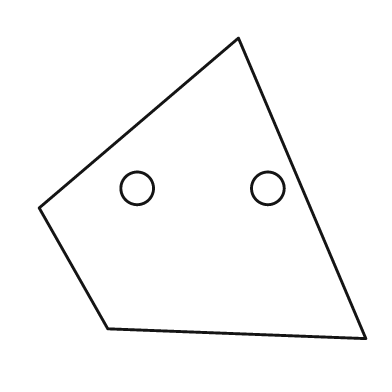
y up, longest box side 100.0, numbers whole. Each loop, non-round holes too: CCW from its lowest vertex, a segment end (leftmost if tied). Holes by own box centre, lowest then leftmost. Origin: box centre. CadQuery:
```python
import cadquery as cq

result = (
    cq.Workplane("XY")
    .moveTo(50.0, -46.0)
    .lineTo(11.0, 46.0)
    .lineTo(-50.0, -6.0)
    .lineTo(-29.0, -43.0)
    .close()
    .moveTo(-20.0, 0.0)
    .circle(5.0)
    .moveTo(20.0, 0.0)
    .circle(5.0)
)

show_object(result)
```